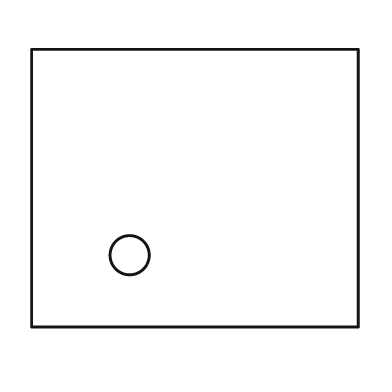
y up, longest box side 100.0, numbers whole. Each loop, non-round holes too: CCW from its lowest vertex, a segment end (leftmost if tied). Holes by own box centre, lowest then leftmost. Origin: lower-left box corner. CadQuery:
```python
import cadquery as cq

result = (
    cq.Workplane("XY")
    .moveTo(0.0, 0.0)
    .lineTo(100.0, 0.0)
    .lineTo(100.0, 85.0)
    .lineTo(0.0, 85.0)
    .close()
    .moveTo(30.0, 22.0)
    .circle(6.0)
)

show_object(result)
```